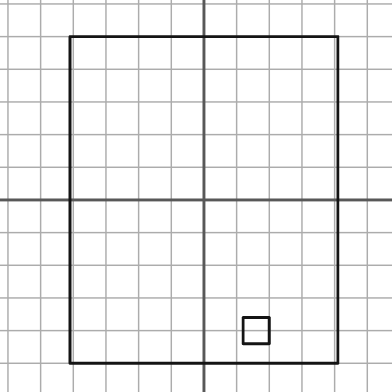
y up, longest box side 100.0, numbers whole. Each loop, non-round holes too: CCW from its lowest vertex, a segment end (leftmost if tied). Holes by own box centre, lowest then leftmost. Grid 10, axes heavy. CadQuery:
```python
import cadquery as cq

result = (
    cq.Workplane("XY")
    .moveTo(-41.0, -50.0)
    .lineTo(41.0, -50.0)
    .lineTo(41.0, 50.0)
    .lineTo(-41.0, 50.0)
    .close()
    .moveTo(12.0, -44.0)
    .lineTo(20.0, -44.0)
    .lineTo(20.0, -36.0)
    .lineTo(12.0, -36.0)
    .close()
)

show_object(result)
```